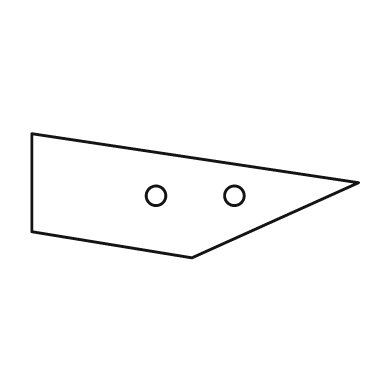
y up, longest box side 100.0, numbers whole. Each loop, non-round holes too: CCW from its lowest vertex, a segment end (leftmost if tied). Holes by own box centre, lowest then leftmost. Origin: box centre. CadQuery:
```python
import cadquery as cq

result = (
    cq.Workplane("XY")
    .moveTo(-1.0, -19.0)
    .lineTo(50.0, 4.0)
    .lineTo(-50.0, 19.0)
    .lineTo(-50.0, -11.0)
    .close()
    .moveTo(-12.0, 0.0)
    .circle(3.0)
    .moveTo(12.0, 0.0)
    .circle(3.0)
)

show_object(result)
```